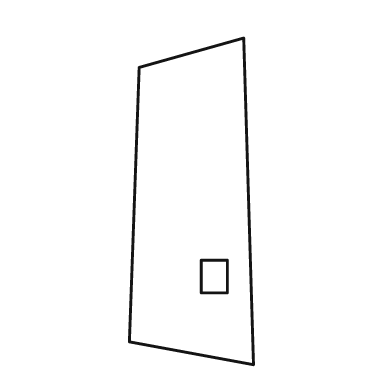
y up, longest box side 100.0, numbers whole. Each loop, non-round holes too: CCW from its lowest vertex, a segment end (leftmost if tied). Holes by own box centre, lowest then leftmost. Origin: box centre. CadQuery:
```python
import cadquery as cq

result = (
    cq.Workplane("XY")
    .moveTo(19.0, -50.0)
    .lineTo(16.0, 50.0)
    .lineTo(-16.0, 41.0)
    .lineTo(-19.0, -43.0)
    .close()
    .moveTo(3.0, -28.0)
    .lineTo(11.0, -28.0)
    .lineTo(11.0, -18.0)
    .lineTo(3.0, -18.0)
    .close()
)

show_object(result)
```